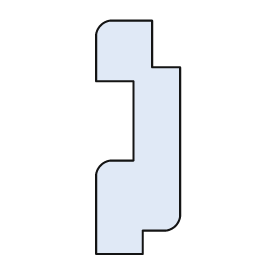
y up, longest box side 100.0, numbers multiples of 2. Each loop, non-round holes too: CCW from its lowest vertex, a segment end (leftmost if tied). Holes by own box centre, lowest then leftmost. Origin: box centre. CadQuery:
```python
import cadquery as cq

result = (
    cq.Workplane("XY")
    .moveTo(-18.0, -50.0)
    .lineTo(2.0, -50.0)
    .lineTo(2.0, -40.0)
    .lineTo(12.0, -40.0)
    .threePointArc((16.0, -38.0), (18.0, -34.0))
    .lineTo(18.0, 30.0)
    .lineTo(6.0, 30.0)
    .lineTo(6.0, 50.0)
    .lineTo(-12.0, 50.0)
    .threePointArc((-16.0, 48.0), (-18.0, 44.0))
    .lineTo(-18.0, 24.0)
    .lineTo(-2.0, 24.0)
    .lineTo(-2.0, -10.0)
    .lineTo(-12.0, -10.0)
    .threePointArc((-16.0, -12.0), (-18.0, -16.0))
    .close()
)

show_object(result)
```